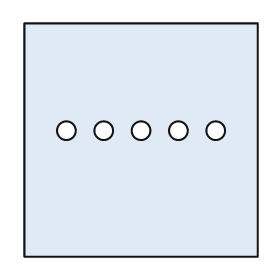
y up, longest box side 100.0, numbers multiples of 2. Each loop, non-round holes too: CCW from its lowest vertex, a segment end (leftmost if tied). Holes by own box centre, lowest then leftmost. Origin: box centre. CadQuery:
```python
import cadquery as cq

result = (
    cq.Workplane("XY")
    .moveTo(-50.0, -50.0)
    .lineTo(50.0, -50.0)
    .lineTo(50.0, 50.0)
    .lineTo(-50.0, 50.0)
    .close()
    .moveTo(-32.0, 4.0)
    .circle(4.0)
    .moveTo(-16.0, 4.0)
    .circle(4.0)
    .moveTo(0.0, 4.0)
    .circle(4.0)
    .moveTo(16.0, 4.0)
    .circle(4.0)
    .moveTo(32.0, 4.0)
    .circle(4.0)
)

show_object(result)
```